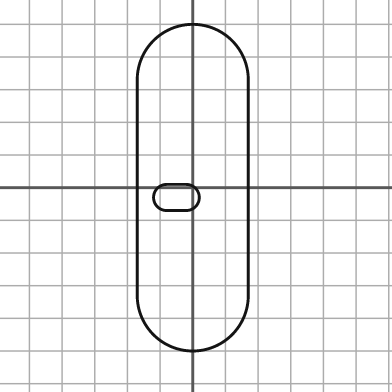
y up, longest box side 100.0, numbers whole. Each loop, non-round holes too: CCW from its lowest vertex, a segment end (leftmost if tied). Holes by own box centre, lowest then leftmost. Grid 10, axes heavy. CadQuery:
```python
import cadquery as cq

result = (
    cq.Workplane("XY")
    .moveTo(-17.0, -33.0)
    .threePointArc((0.0, -50.0), (17.0, -33.0))
    .lineTo(17.0, 33.0)
    .threePointArc((0.0, 50.0), (-17.0, 33.0))
    .close()
    .moveTo(-8.0, -7.0)
    .lineTo(-2.0, -7.0)
    .threePointArc((2.0, -3.0), (-2.0, 1.0))
    .lineTo(-8.0, 1.0)
    .threePointArc((-12.0, -3.0), (-8.0, -7.0))
    .close()
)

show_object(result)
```